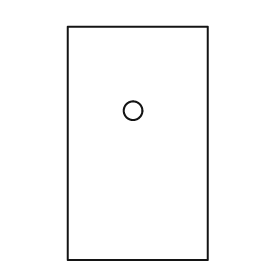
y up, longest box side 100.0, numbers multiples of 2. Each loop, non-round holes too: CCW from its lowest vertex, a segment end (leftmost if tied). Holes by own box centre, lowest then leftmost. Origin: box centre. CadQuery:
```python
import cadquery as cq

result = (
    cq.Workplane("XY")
    .moveTo(-30.0, -50.0)
    .lineTo(30.0, -50.0)
    .lineTo(30.0, 50.0)
    .lineTo(-30.0, 50.0)
    .close()
    .moveTo(-2.0, 14.0)
    .circle(4.0)
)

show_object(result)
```